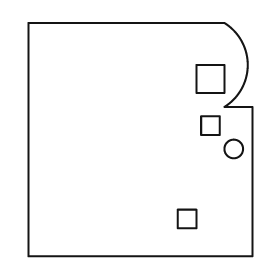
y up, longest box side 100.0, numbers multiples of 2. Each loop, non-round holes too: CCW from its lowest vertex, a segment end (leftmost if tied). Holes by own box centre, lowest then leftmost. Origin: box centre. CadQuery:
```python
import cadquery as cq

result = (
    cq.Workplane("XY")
    .moveTo(-48.0, -50.0)
    .lineTo(48.0, -50.0)
    .lineTo(48.0, 14.0)
    .lineTo(36.0, 14.0)
    .threePointArc((46.0, 32.0), (36.0, 50.0))
    .lineTo(-48.0, 50.0)
    .close()
    .moveTo(16.0, -38.0)
    .lineTo(24.0, -38.0)
    .lineTo(24.0, -30.0)
    .lineTo(16.0, -30.0)
    .close()
    .moveTo(40.0, -4.0)
    .circle(4.0)
    .moveTo(26.0, 2.0)
    .lineTo(34.0, 2.0)
    .lineTo(34.0, 10.0)
    .lineTo(26.0, 10.0)
    .close()
    .moveTo(24.0, 20.0)
    .lineTo(36.0, 20.0)
    .lineTo(36.0, 32.0)
    .lineTo(24.0, 32.0)
    .close()
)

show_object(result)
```